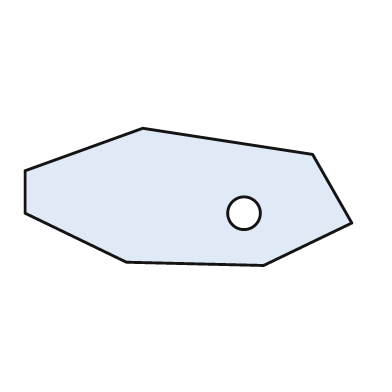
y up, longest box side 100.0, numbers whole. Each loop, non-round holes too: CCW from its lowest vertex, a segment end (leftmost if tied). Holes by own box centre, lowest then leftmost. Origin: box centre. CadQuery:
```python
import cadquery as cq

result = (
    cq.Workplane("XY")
    .moveTo(23.0, -21.0)
    .lineTo(50.0, -8.0)
    .lineTo(38.0, 13.0)
    .lineTo(-14.0, 21.0)
    .lineTo(-50.0, 8.0)
    .lineTo(-50.0, -5.0)
    .lineTo(-19.0, -20.0)
    .close()
    .moveTo(17.0, -5.0)
    .circle(5.0)
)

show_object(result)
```